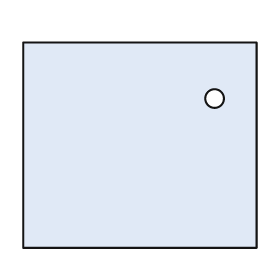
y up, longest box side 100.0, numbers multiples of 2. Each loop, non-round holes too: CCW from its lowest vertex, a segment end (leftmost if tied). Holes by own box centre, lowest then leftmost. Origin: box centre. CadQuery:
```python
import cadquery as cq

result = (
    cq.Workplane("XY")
    .moveTo(-50.0, -44.0)
    .lineTo(50.0, -44.0)
    .lineTo(50.0, 44.0)
    .lineTo(-50.0, 44.0)
    .close()
    .moveTo(32.0, 20.0)
    .circle(4.0)
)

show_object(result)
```